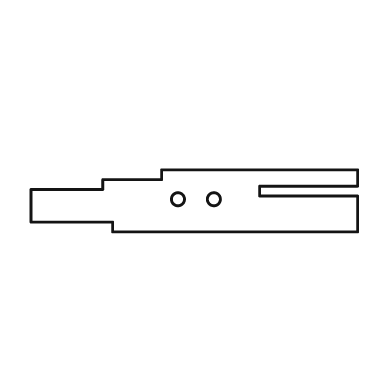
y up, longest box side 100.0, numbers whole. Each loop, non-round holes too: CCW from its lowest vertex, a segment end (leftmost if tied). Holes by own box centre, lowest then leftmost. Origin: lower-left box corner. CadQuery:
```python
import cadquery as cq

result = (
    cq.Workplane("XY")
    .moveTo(25.0, 0.0)
    .lineTo(100.0, 0.0)
    .lineTo(100.0, 11.0)
    .lineTo(70.0, 11.0)
    .lineTo(70.0, 14.0)
    .lineTo(100.0, 14.0)
    .lineTo(100.0, 19.0)
    .lineTo(40.0, 19.0)
    .lineTo(40.0, 16.0)
    .lineTo(22.0, 16.0)
    .lineTo(22.0, 13.0)
    .lineTo(0.0, 13.0)
    .lineTo(0.0, 3.0)
    .lineTo(25.0, 3.0)
    .close()
    .moveTo(45.0, 10.0)
    .circle(2.0)
    .moveTo(56.0, 10.0)
    .circle(2.0)
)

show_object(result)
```